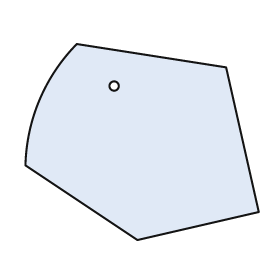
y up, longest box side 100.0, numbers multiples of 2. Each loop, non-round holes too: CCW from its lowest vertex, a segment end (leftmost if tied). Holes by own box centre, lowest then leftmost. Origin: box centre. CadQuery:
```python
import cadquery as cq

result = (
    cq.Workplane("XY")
    .moveTo(-2.0, -42.0)
    .lineTo(50.0, -30.0)
    .lineTo(36.0, 32.0)
    .lineTo(-28.0, 42.0)
    .threePointArc((-44.0, 18.0), (-50.0, -10.0))
    .close()
    .moveTo(-12.0, 24.0)
    .circle(2.0)
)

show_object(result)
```